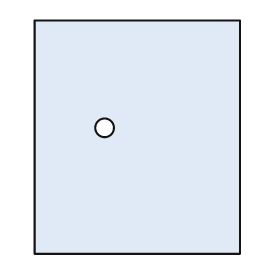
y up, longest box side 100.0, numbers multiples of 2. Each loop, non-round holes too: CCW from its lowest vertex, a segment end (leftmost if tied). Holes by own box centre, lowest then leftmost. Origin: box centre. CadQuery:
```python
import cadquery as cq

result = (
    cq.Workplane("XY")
    .moveTo(-44.0, -50.0)
    .lineTo(44.0, -50.0)
    .lineTo(44.0, 50.0)
    .lineTo(-44.0, 50.0)
    .close()
    .moveTo(-14.0, 4.0)
    .circle(4.0)
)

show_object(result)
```